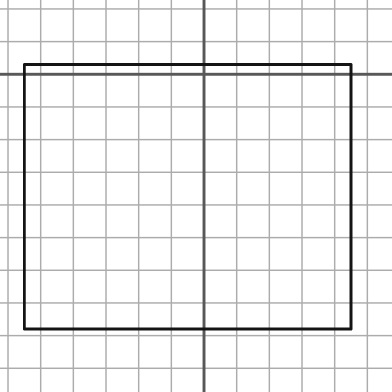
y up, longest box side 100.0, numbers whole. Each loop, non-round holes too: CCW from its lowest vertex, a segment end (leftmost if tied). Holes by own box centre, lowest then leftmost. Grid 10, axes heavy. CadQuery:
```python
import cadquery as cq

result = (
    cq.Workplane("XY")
    .moveTo(-55.0, -78.0)
    .lineTo(45.0, -78.0)
    .lineTo(45.0, 3.0)
    .lineTo(-55.0, 3.0)
    .close()
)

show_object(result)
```